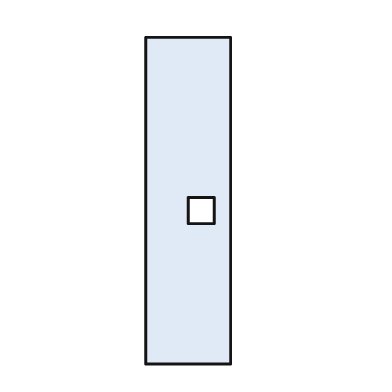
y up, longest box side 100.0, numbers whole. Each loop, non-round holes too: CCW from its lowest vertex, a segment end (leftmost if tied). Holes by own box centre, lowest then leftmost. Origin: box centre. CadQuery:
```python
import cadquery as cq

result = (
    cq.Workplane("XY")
    .moveTo(-13.0, -50.0)
    .lineTo(13.0, -50.0)
    .lineTo(13.0, 50.0)
    .lineTo(-13.0, 50.0)
    .close()
    .moveTo(0.0, -7.0)
    .lineTo(8.0, -7.0)
    .lineTo(8.0, 1.0)
    .lineTo(0.0, 1.0)
    .close()
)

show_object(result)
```